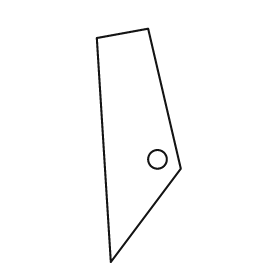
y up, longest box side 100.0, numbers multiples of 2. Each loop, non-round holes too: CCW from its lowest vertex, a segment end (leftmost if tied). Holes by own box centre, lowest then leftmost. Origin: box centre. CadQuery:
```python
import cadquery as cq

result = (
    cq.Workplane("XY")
    .moveTo(-12.0, -50.0)
    .lineTo(18.0, -10.0)
    .lineTo(4.0, 50.0)
    .lineTo(-18.0, 46.0)
    .close()
    .moveTo(8.0, -6.0)
    .circle(4.0)
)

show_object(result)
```